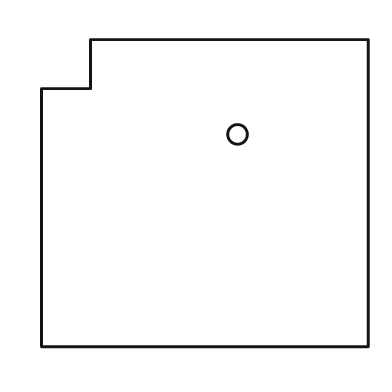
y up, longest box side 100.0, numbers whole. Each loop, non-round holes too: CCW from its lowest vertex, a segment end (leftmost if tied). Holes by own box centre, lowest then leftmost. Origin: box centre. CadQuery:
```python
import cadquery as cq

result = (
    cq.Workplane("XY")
    .moveTo(-50.0, -47.0)
    .lineTo(50.0, -47.0)
    .lineTo(50.0, 47.0)
    .lineTo(-35.0, 47.0)
    .lineTo(-35.0, 32.0)
    .lineTo(-50.0, 32.0)
    .close()
    .moveTo(10.0, 18.0)
    .circle(3.0)
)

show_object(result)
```